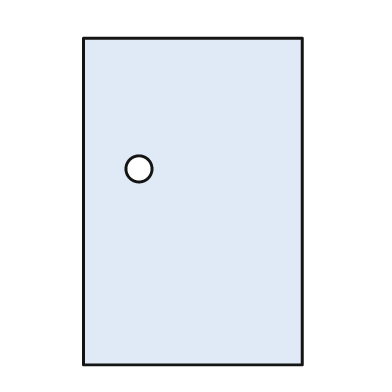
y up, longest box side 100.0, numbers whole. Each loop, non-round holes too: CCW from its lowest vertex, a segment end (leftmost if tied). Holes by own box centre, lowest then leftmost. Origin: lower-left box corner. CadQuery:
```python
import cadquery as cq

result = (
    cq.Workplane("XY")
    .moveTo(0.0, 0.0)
    .lineTo(67.0, 0.0)
    .lineTo(67.0, 100.0)
    .lineTo(0.0, 100.0)
    .close()
    .moveTo(17.0, 60.0)
    .circle(4.0)
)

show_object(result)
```